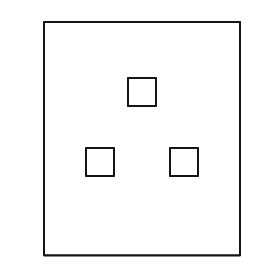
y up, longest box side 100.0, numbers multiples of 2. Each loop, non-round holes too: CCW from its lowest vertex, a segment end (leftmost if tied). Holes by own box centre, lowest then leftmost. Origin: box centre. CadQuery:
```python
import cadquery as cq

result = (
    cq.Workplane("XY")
    .moveTo(-42.0, -50.0)
    .lineTo(42.0, -50.0)
    .lineTo(42.0, 50.0)
    .lineTo(-42.0, 50.0)
    .close()
    .moveTo(-24.0, -16.0)
    .lineTo(-12.0, -16.0)
    .lineTo(-12.0, -4.0)
    .lineTo(-24.0, -4.0)
    .close()
    .moveTo(12.0, -16.0)
    .lineTo(24.0, -16.0)
    .lineTo(24.0, -4.0)
    .lineTo(12.0, -4.0)
    .close()
    .moveTo(-6.0, 14.0)
    .lineTo(6.0, 14.0)
    .lineTo(6.0, 26.0)
    .lineTo(-6.0, 26.0)
    .close()
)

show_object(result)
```